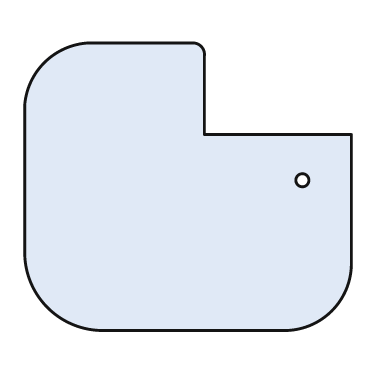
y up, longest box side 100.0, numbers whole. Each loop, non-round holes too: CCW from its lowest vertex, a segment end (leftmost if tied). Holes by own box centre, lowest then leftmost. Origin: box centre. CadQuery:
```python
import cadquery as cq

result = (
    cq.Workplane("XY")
    .moveTo(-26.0, -44.0)
    .lineTo(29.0, -44.0)
    .threePointArc((44.0, -38.0), (50.0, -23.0))
    .lineTo(50.0, 16.0)
    .lineTo(5.0, 16.0)
    .lineTo(5.0, 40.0)
    .threePointArc((4.0, 43.0), (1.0, 44.0))
    .lineTo(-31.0, 44.0)
    .threePointArc((-44.0, 38.0), (-50.0, 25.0))
    .lineTo(-50.0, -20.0)
    .threePointArc((-43.0, -37.0), (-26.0, -44.0))
    .close()
    .moveTo(35.0, 2.0)
    .circle(2.0)
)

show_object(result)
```